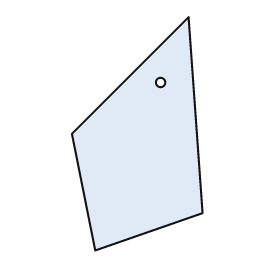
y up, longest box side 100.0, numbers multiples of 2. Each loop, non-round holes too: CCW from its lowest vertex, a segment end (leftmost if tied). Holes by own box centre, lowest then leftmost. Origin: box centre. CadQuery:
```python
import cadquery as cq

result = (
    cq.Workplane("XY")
    .moveTo(-18.0, -50.0)
    .lineTo(28.0, -34.0)
    .lineTo(22.0, 50.0)
    .lineTo(-28.0, 0.0)
    .close()
    .moveTo(10.0, 22.0)
    .circle(2.0)
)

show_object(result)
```